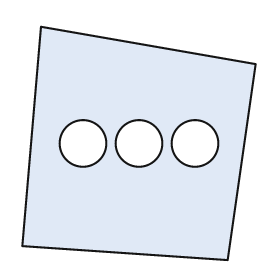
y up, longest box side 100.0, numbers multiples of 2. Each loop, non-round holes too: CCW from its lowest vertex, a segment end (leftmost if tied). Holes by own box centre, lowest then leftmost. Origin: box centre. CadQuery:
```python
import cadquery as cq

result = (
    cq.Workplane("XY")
    .moveTo(38.0, -50.0)
    .lineTo(50.0, 34.0)
    .lineTo(-42.0, 50.0)
    .lineTo(-50.0, -44.0)
    .close()
    .moveTo(-24.0, 0.0)
    .circle(10.0)
    .moveTo(0.0, 0.0)
    .circle(10.0)
    .moveTo(24.0, 0.0)
    .circle(10.0)
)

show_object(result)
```